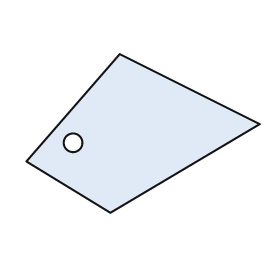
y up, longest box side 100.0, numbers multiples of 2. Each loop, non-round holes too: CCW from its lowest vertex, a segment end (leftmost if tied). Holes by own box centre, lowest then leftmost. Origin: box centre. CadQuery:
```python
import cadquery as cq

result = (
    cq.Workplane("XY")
    .moveTo(-14.0, -34.0)
    .lineTo(50.0, 4.0)
    .lineTo(-10.0, 34.0)
    .lineTo(-50.0, -12.0)
    .close()
    .moveTo(-30.0, -4.0)
    .circle(4.0)
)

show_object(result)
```